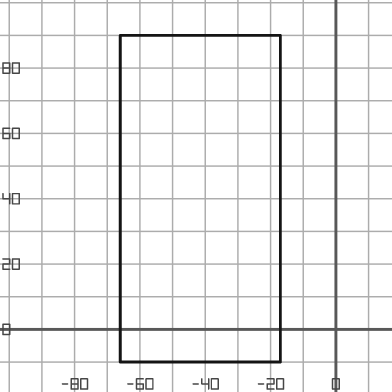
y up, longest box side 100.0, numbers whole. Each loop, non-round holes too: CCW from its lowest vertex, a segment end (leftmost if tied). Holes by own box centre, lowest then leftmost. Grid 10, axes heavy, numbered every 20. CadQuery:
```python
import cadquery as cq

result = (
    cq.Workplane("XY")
    .moveTo(-66.0, -10.0)
    .lineTo(-17.0, -10.0)
    .lineTo(-17.0, 90.0)
    .lineTo(-66.0, 90.0)
    .close()
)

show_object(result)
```